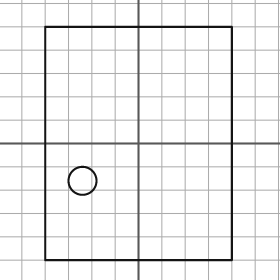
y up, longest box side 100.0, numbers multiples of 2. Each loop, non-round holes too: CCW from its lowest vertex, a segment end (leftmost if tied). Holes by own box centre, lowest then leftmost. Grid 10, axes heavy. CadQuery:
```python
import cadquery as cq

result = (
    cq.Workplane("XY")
    .moveTo(-40.0, -50.0)
    .lineTo(40.0, -50.0)
    .lineTo(40.0, 50.0)
    .lineTo(-40.0, 50.0)
    .close()
    .moveTo(-24.0, -16.0)
    .circle(6.0)
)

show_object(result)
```